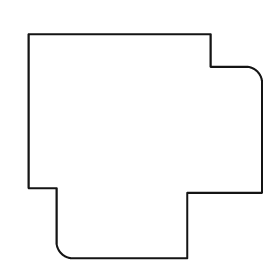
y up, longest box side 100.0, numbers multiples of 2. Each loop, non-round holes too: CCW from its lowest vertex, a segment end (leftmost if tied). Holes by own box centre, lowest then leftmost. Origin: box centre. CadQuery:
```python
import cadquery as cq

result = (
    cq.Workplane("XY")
    .moveTo(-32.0, -48.0)
    .lineTo(18.0, -48.0)
    .lineTo(18.0, -20.0)
    .lineTo(50.0, -20.0)
    .lineTo(50.0, 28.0)
    .threePointArc((48.0, 32.0), (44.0, 34.0))
    .lineTo(28.0, 34.0)
    .lineTo(28.0, 48.0)
    .lineTo(-50.0, 48.0)
    .lineTo(-50.0, -18.0)
    .lineTo(-38.0, -18.0)
    .lineTo(-38.0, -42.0)
    .threePointArc((-36.0, -46.0), (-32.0, -48.0))
    .close()
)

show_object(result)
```